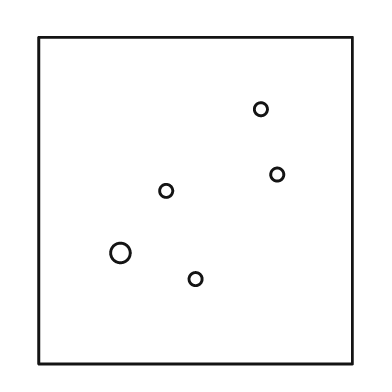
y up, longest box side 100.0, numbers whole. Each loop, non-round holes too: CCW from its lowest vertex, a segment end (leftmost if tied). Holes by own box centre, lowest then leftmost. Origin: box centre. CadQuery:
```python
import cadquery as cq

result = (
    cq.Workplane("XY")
    .moveTo(-48.0, -50.0)
    .lineTo(48.0, -50.0)
    .lineTo(48.0, 50.0)
    .lineTo(-48.0, 50.0)
    .close()
    .moveTo(0.0, -24.0)
    .circle(2.0)
    .moveTo(-23.0, -16.0)
    .circle(3.0)
    .moveTo(-9.0, 3.0)
    .circle(2.0)
    .moveTo(25.0, 8.0)
    .circle(2.0)
    .moveTo(20.0, 28.0)
    .circle(2.0)
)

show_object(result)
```